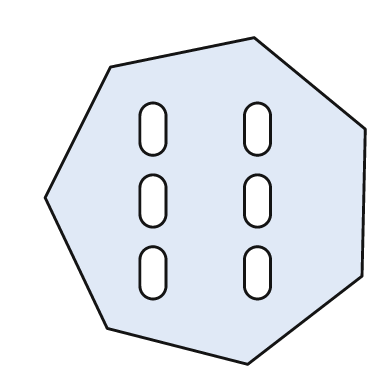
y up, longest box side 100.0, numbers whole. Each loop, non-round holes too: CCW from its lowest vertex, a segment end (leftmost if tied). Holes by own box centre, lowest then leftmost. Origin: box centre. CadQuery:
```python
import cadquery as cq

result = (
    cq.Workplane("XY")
    .moveTo(13.0, -50.0)
    .lineTo(48.0, -23.0)
    .lineTo(49.0, 22.0)
    .lineTo(15.0, 50.0)
    .lineTo(-29.0, 41.0)
    .lineTo(-49.0, 1.0)
    .lineTo(-30.0, -39.0)
    .close()
    .moveTo(-20.0, -26.0)
    .threePointArc((-16.0, -30.0), (-12.0, -26.0))
    .lineTo(-12.0, -18.0)
    .threePointArc((-16.0, -14.0), (-20.0, -18.0))
    .close()
    .moveTo(12.0, -26.0)
    .threePointArc((16.0, -30.0), (20.0, -26.0))
    .lineTo(20.0, -18.0)
    .threePointArc((16.0, -14.0), (12.0, -18.0))
    .close()
    .moveTo(-20.0, -4.0)
    .threePointArc((-16.0, -8.0), (-12.0, -4.0))
    .lineTo(-12.0, 4.0)
    .threePointArc((-16.0, 8.0), (-20.0, 4.0))
    .close()
    .moveTo(12.0, -4.0)
    .threePointArc((16.0, -8.0), (20.0, -4.0))
    .lineTo(20.0, 4.0)
    .threePointArc((16.0, 8.0), (12.0, 4.0))
    .close()
    .moveTo(-20.0, 18.0)
    .threePointArc((-16.0, 14.0), (-12.0, 18.0))
    .lineTo(-12.0, 26.0)
    .threePointArc((-16.0, 30.0), (-20.0, 26.0))
    .close()
    .moveTo(12.0, 18.0)
    .threePointArc((16.0, 14.0), (20.0, 18.0))
    .lineTo(20.0, 26.0)
    .threePointArc((16.0, 30.0), (12.0, 26.0))
    .close()
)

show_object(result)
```